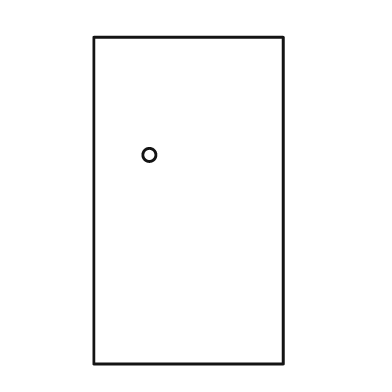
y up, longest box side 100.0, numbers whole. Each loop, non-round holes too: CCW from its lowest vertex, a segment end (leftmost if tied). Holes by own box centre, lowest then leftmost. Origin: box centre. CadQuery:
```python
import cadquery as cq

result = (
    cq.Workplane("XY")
    .moveTo(-29.0, -50.0)
    .lineTo(29.0, -50.0)
    .lineTo(29.0, 50.0)
    .lineTo(-29.0, 50.0)
    .close()
    .moveTo(-12.0, 14.0)
    .circle(2.0)
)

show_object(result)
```